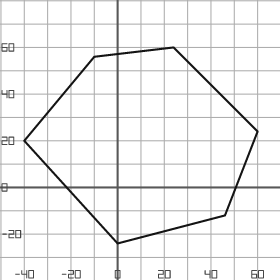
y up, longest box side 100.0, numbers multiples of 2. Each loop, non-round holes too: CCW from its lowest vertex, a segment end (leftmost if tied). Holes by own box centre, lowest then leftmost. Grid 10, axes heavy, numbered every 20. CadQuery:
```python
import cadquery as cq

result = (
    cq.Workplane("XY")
    .moveTo(0.0, -24.0)
    .lineTo(46.0, -12.0)
    .lineTo(60.0, 24.0)
    .lineTo(24.0, 60.0)
    .lineTo(-10.0, 56.0)
    .lineTo(-40.0, 20.0)
    .close()
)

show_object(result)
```